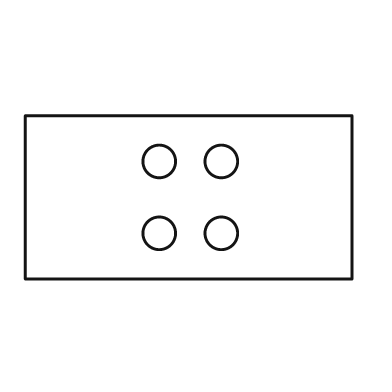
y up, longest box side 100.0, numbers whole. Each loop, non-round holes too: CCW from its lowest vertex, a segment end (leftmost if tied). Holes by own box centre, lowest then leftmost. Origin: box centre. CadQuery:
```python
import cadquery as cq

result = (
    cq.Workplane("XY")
    .moveTo(-50.0, -25.0)
    .lineTo(50.0, -25.0)
    .lineTo(50.0, 25.0)
    .lineTo(-50.0, 25.0)
    .close()
    .moveTo(-9.0, -11.0)
    .circle(5.0)
    .moveTo(10.0, -11.0)
    .circle(5.0)
    .moveTo(-9.0, 11.0)
    .circle(5.0)
    .moveTo(10.0, 11.0)
    .circle(5.0)
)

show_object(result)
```